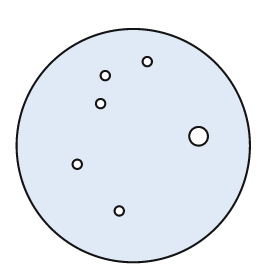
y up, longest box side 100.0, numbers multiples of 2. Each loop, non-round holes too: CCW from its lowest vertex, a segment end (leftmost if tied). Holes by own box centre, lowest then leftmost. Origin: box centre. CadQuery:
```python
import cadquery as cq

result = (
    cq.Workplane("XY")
    .moveTo(0.0, 0.0)
    .circle(50.0)
    .moveTo(-6.0, -28.0)
    .circle(2.0)
    .moveTo(-24.0, -8.0)
    .circle(2.0)
    .moveTo(28.0, 4.0)
    .circle(4.0)
    .moveTo(-14.0, 18.0)
    .circle(2.0)
    .moveTo(-12.0, 30.0)
    .circle(2.0)
    .moveTo(6.0, 36.0)
    .circle(2.0)
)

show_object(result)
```